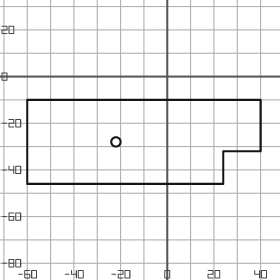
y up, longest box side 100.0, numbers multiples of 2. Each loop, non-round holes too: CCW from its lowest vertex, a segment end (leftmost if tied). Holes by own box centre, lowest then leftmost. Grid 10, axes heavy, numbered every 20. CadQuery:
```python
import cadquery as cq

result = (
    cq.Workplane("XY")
    .moveTo(-60.0, -46.0)
    .lineTo(24.0, -46.0)
    .lineTo(24.0, -32.0)
    .lineTo(40.0, -32.0)
    .lineTo(40.0, -10.0)
    .lineTo(-60.0, -10.0)
    .close()
    .moveTo(-22.0, -28.0)
    .circle(2.0)
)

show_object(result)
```